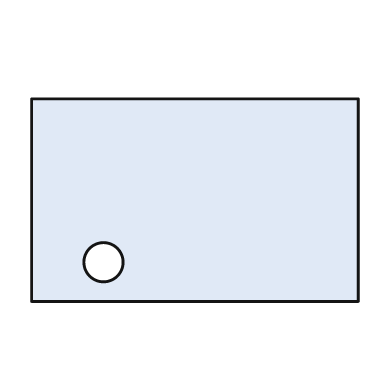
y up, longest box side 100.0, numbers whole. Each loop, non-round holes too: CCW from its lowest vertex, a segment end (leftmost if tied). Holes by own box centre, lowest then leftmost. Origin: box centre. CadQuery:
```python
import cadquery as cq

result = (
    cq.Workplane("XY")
    .moveTo(-50.0, -31.0)
    .lineTo(50.0, -31.0)
    .lineTo(50.0, 31.0)
    .lineTo(-50.0, 31.0)
    .close()
    .moveTo(-28.0, -19.0)
    .circle(6.0)
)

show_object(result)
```